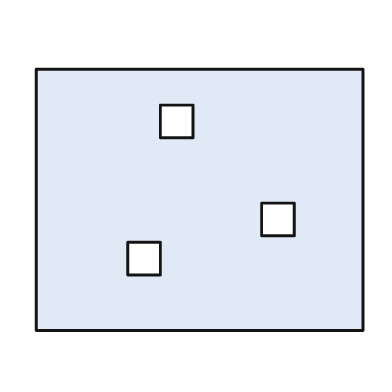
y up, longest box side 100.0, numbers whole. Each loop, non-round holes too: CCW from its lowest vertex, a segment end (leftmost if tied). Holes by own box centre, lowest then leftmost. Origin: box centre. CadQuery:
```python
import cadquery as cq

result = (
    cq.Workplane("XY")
    .moveTo(-50.0, -40.0)
    .lineTo(50.0, -40.0)
    .lineTo(50.0, 40.0)
    .lineTo(-50.0, 40.0)
    .close()
    .moveTo(-22.0, -23.0)
    .lineTo(-12.0, -23.0)
    .lineTo(-12.0, -13.0)
    .lineTo(-22.0, -13.0)
    .close()
    .moveTo(19.0, -11.0)
    .lineTo(29.0, -11.0)
    .lineTo(29.0, -1.0)
    .lineTo(19.0, -1.0)
    .close()
    .moveTo(-12.0, 19.0)
    .lineTo(-2.0, 19.0)
    .lineTo(-2.0, 29.0)
    .lineTo(-12.0, 29.0)
    .close()
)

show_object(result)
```